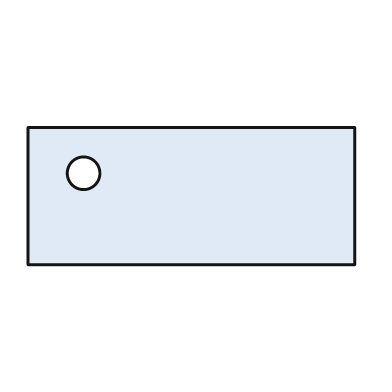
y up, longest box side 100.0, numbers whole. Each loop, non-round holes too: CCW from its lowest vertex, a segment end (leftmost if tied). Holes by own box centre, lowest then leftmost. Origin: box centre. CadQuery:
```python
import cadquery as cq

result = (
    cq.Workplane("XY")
    .moveTo(-50.0, -21.0)
    .lineTo(50.0, -21.0)
    .lineTo(50.0, 21.0)
    .lineTo(-50.0, 21.0)
    .close()
    .moveTo(-33.0, 7.0)
    .circle(5.0)
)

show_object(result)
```